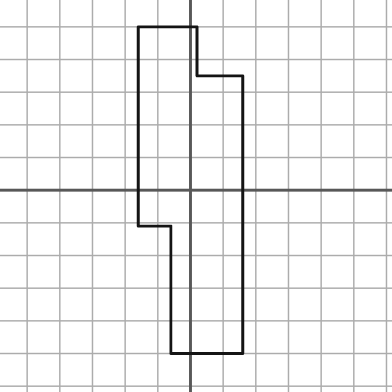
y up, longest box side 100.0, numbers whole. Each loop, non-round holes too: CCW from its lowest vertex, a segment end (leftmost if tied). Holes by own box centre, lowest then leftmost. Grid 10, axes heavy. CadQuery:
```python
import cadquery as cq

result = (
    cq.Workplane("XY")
    .moveTo(-6.0, -50.0)
    .lineTo(16.0, -50.0)
    .lineTo(16.0, 35.0)
    .lineTo(2.0, 35.0)
    .lineTo(2.0, 50.0)
    .lineTo(-16.0, 50.0)
    .lineTo(-16.0, -11.0)
    .lineTo(-6.0, -11.0)
    .close()
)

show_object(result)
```